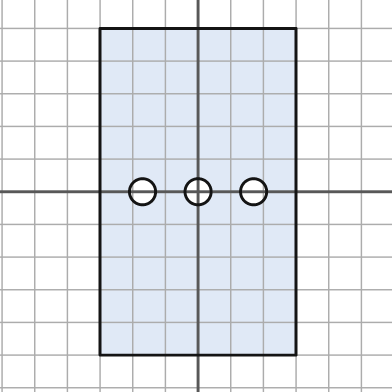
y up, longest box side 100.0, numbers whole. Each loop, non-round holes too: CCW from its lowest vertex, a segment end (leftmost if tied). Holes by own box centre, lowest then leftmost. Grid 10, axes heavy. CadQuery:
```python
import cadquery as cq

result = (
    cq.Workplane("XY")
    .moveTo(-30.0, -50.0)
    .lineTo(30.0, -50.0)
    .lineTo(30.0, 50.0)
    .lineTo(-30.0, 50.0)
    .close()
    .moveTo(-17.0, 0.0)
    .circle(4.0)
    .moveTo(0.0, 0.0)
    .circle(4.0)
    .moveTo(17.0, 0.0)
    .circle(4.0)
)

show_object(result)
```